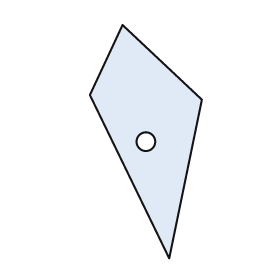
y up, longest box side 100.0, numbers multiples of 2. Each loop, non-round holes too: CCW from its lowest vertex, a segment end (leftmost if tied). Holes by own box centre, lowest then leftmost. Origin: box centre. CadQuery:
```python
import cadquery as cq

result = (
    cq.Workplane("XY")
    .moveTo(10.0, -50.0)
    .lineTo(24.0, 18.0)
    .lineTo(-10.0, 50.0)
    .lineTo(-24.0, 20.0)
    .close()
    .moveTo(0.0, 0.0)
    .circle(4.0)
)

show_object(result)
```